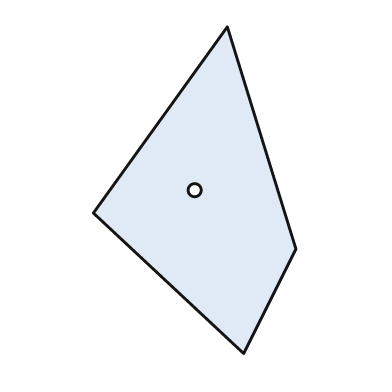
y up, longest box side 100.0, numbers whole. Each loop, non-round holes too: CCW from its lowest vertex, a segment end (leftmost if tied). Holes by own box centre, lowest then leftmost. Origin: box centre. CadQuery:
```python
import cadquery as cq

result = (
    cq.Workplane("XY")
    .moveTo(15.0, -50.0)
    .lineTo(31.0, -18.0)
    .lineTo(10.0, 50.0)
    .lineTo(-31.0, -7.0)
    .close()
    .moveTo(0.0, 0.0)
    .circle(2.0)
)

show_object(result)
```